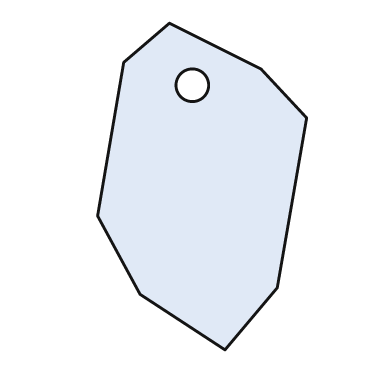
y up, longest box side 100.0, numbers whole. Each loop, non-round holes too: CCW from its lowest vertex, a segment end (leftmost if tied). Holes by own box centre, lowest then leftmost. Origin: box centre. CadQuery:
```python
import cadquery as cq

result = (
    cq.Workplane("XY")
    .moveTo(7.0, -50.0)
    .lineTo(23.0, -31.0)
    .lineTo(32.0, 21.0)
    .lineTo(18.0, 36.0)
    .lineTo(-10.0, 50.0)
    .lineTo(-24.0, 38.0)
    .lineTo(-32.0, -9.0)
    .lineTo(-19.0, -33.0)
    .close()
    .moveTo(-3.0, 31.0)
    .circle(5.0)
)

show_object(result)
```